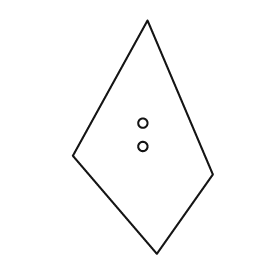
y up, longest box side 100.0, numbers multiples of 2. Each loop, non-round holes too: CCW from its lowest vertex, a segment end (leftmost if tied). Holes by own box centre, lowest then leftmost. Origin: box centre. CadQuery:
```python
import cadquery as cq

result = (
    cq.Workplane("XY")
    .moveTo(6.0, -50.0)
    .lineTo(30.0, -16.0)
    .lineTo(2.0, 50.0)
    .lineTo(-30.0, -8.0)
    .close()
    .moveTo(0.0, -4.0)
    .circle(2.0)
    .moveTo(0.0, 6.0)
    .circle(2.0)
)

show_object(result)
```